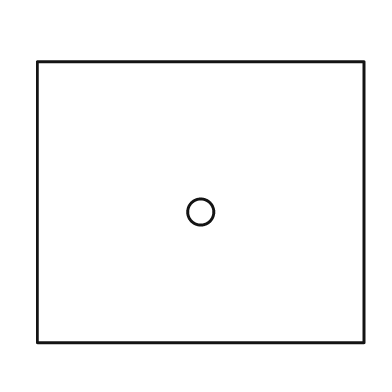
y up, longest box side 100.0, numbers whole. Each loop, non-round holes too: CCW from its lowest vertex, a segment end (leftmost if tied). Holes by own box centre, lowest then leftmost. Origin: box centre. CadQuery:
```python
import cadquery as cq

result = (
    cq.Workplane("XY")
    .moveTo(-50.0, -43.0)
    .lineTo(50.0, -43.0)
    .lineTo(50.0, 43.0)
    .lineTo(-50.0, 43.0)
    .close()
    .moveTo(0.0, -3.0)
    .circle(4.0)
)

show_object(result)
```